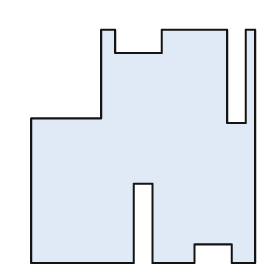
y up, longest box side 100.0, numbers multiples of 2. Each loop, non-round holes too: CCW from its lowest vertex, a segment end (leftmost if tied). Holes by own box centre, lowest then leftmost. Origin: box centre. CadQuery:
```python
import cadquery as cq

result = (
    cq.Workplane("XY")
    .moveTo(-48.0, -50.0)
    .lineTo(-4.0, -50.0)
    .lineTo(-4.0, -16.0)
    .lineTo(4.0, -16.0)
    .lineTo(4.0, -50.0)
    .lineTo(22.0, -50.0)
    .lineTo(22.0, -42.0)
    .lineTo(38.0, -42.0)
    .lineTo(38.0, -50.0)
    .lineTo(48.0, -50.0)
    .lineTo(48.0, 50.0)
    .lineTo(44.0, 50.0)
    .lineTo(44.0, 10.0)
    .lineTo(36.0, 10.0)
    .lineTo(36.0, 50.0)
    .lineTo(8.0, 50.0)
    .lineTo(8.0, 40.0)
    .lineTo(-12.0, 40.0)
    .lineTo(-12.0, 50.0)
    .lineTo(-18.0, 50.0)
    .lineTo(-18.0, 12.0)
    .lineTo(-48.0, 12.0)
    .close()
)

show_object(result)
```